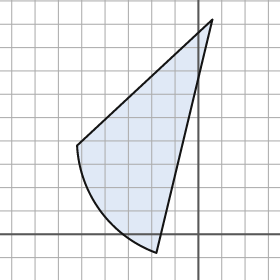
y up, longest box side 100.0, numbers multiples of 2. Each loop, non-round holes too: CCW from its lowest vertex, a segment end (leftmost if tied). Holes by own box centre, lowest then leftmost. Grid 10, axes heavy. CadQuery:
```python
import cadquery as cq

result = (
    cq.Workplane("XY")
    .moveTo(-18.0, -8.0)
    .lineTo(6.0, 92.0)
    .lineTo(-52.0, 38.0)
    .threePointArc((-42.0, 10.0), (-18.0, -8.0))
    .close()
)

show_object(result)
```